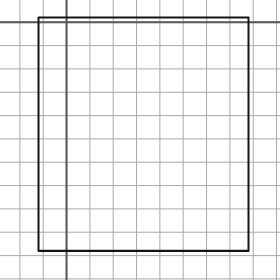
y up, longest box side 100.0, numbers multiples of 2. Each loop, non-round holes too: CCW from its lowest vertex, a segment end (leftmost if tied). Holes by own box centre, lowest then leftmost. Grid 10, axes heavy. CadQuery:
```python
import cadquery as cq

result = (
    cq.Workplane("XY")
    .moveTo(-12.0, -98.0)
    .lineTo(78.0, -98.0)
    .lineTo(78.0, 2.0)
    .lineTo(-12.0, 2.0)
    .close()
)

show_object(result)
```